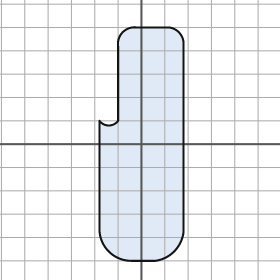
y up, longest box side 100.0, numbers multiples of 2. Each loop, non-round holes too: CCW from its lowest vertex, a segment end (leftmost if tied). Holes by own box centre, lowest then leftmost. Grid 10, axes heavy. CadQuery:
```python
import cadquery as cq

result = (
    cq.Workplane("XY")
    .moveTo(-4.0, -50.0)
    .lineTo(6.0, -50.0)
    .threePointArc((14.0, -46.0), (18.0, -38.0))
    .lineTo(18.0, 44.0)
    .threePointArc((16.0, 48.0), (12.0, 50.0))
    .lineTo(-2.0, 50.0)
    .threePointArc((-8.0, 48.0), (-10.0, 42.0))
    .lineTo(-10.0, 10.0)
    .threePointArc((-14.0, 8.0), (-18.0, 10.0))
    .lineTo(-18.0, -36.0)
    .threePointArc((-14.0, -46.0), (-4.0, -50.0))
    .close()
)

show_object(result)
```